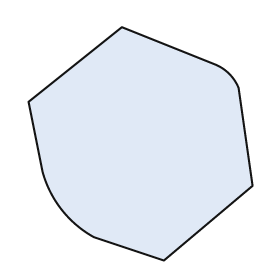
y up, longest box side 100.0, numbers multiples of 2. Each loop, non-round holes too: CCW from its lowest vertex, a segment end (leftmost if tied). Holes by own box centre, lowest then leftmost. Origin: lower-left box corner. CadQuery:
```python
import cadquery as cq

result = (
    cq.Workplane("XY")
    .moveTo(58.0, 0.0)
    .lineTo(96.0, 32.0)
    .lineTo(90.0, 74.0)
    .threePointArc((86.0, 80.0), (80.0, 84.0))
    .lineTo(40.0, 100.0)
    .lineTo(0.0, 68.0)
    .lineTo(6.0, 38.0)
    .threePointArc((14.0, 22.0), (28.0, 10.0))
    .close()
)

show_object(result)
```